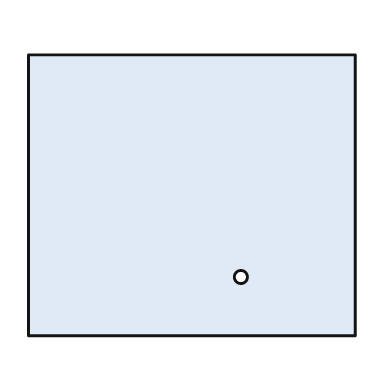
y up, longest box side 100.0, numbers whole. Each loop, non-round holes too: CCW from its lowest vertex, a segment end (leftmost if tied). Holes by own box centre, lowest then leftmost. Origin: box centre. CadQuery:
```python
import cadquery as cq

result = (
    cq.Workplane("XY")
    .moveTo(-50.0, -43.0)
    .lineTo(50.0, -43.0)
    .lineTo(50.0, 43.0)
    .lineTo(-50.0, 43.0)
    .close()
    .moveTo(15.0, -25.0)
    .circle(2.0)
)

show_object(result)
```